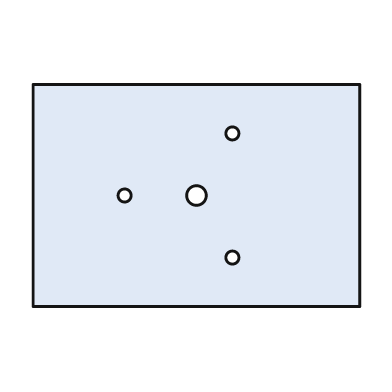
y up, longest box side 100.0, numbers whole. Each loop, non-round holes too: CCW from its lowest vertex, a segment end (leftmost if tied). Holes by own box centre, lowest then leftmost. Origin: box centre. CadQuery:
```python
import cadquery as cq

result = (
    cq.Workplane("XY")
    .moveTo(-50.0, -34.0)
    .lineTo(50.0, -34.0)
    .lineTo(50.0, 34.0)
    .lineTo(-50.0, 34.0)
    .close()
    .moveTo(11.0, -19.0)
    .circle(2.0)
    .moveTo(-22.0, 0.0)
    .circle(2.0)
    .moveTo(0.0, 0.0)
    .circle(3.0)
    .moveTo(11.0, 19.0)
    .circle(2.0)
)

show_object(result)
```